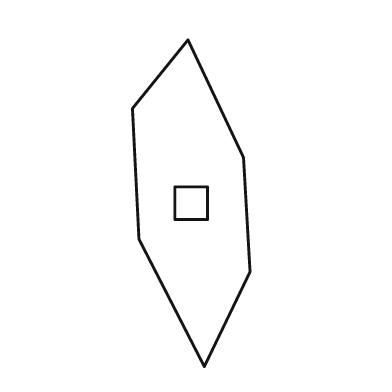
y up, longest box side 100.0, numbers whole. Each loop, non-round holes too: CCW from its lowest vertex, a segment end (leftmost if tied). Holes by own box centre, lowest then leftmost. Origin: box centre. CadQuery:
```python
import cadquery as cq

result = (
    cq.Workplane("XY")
    .moveTo(4.0, -50.0)
    .lineTo(18.0, -21.0)
    .lineTo(16.0, 14.0)
    .lineTo(-1.0, 50.0)
    .lineTo(-18.0, 29.0)
    .lineTo(-16.0, -11.0)
    .close()
    .moveTo(-5.0, -5.0)
    .lineTo(5.0, -5.0)
    .lineTo(5.0, 5.0)
    .lineTo(-5.0, 5.0)
    .close()
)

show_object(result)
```